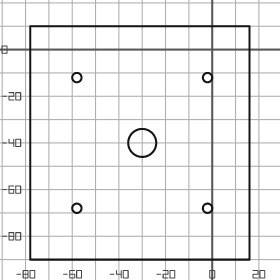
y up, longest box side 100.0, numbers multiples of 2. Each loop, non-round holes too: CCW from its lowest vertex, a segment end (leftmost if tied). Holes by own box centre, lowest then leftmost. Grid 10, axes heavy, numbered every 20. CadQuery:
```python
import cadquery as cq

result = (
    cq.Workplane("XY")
    .moveTo(-78.0, -90.0)
    .lineTo(16.0, -90.0)
    .lineTo(16.0, 10.0)
    .lineTo(-78.0, 10.0)
    .close()
    .moveTo(-58.0, -68.0)
    .circle(2.0)
    .moveTo(-2.0, -68.0)
    .circle(2.0)
    .moveTo(-30.0, -40.0)
    .circle(6.0)
    .moveTo(-58.0, -12.0)
    .circle(2.0)
    .moveTo(-2.0, -12.0)
    .circle(2.0)
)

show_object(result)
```